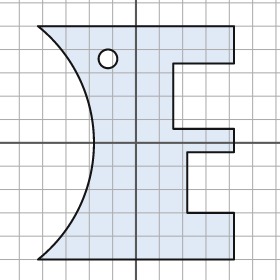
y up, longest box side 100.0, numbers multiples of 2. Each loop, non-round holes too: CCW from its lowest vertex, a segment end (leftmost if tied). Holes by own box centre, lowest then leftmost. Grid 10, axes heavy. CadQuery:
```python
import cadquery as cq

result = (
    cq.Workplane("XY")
    .moveTo(-42.0, -50.0)
    .lineTo(42.0, -50.0)
    .lineTo(42.0, -30.0)
    .lineTo(22.0, -30.0)
    .lineTo(22.0, -4.0)
    .lineTo(42.0, -4.0)
    .lineTo(42.0, 6.0)
    .lineTo(16.0, 6.0)
    .lineTo(16.0, 34.0)
    .lineTo(42.0, 34.0)
    .lineTo(42.0, 50.0)
    .lineTo(-42.0, 50.0)
    .threePointArc((-18.0, 0.0), (-42.0, -50.0))
    .close()
    .moveTo(-12.0, 36.0)
    .circle(4.0)
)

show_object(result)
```